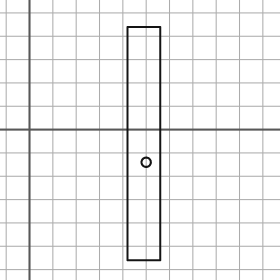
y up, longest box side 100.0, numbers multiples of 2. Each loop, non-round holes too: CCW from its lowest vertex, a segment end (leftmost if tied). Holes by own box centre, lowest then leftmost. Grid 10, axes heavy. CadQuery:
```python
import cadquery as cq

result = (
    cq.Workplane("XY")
    .moveTo(42.0, -56.0)
    .lineTo(56.0, -56.0)
    .lineTo(56.0, 44.0)
    .lineTo(42.0, 44.0)
    .close()
    .moveTo(50.0, -14.0)
    .circle(2.0)
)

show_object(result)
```